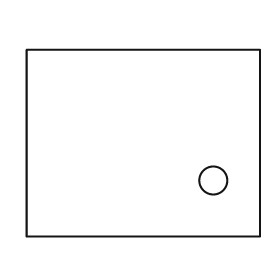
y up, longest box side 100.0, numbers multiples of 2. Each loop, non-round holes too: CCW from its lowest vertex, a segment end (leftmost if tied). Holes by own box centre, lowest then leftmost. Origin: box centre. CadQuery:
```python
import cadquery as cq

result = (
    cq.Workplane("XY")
    .moveTo(-50.0, -40.0)
    .lineTo(50.0, -40.0)
    .lineTo(50.0, 40.0)
    .lineTo(-50.0, 40.0)
    .close()
    .moveTo(30.0, -16.0)
    .circle(6.0)
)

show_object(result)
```